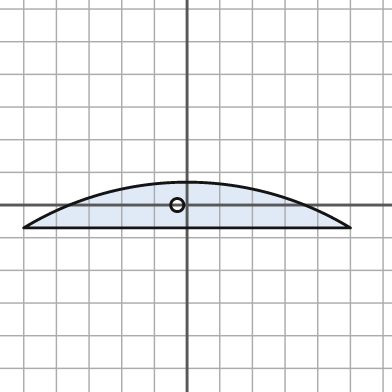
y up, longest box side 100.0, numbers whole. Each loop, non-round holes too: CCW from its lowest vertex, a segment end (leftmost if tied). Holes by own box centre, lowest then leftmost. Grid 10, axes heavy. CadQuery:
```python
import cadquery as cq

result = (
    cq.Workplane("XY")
    .moveTo(-50.0, -7.0)
    .lineTo(50.0, -7.0)
    .threePointArc((0.0, 7.0), (-50.0, -7.0))
    .close()
    .moveTo(-3.0, 0.0)
    .circle(2.0)
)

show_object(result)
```